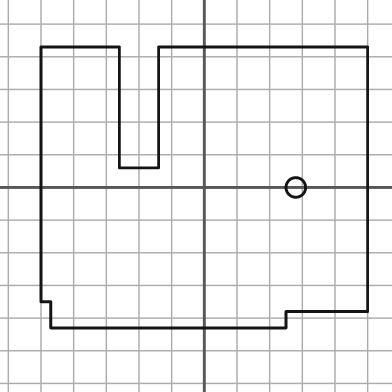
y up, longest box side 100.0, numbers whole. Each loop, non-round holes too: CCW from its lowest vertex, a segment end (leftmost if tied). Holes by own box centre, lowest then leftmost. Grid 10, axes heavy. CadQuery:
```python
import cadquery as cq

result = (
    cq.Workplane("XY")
    .moveTo(-47.0, -43.0)
    .lineTo(25.0, -43.0)
    .lineTo(25.0, -38.0)
    .lineTo(50.0, -38.0)
    .lineTo(50.0, 43.0)
    .lineTo(-14.0, 43.0)
    .lineTo(-14.0, 6.0)
    .lineTo(-26.0, 6.0)
    .lineTo(-26.0, 43.0)
    .lineTo(-50.0, 43.0)
    .lineTo(-50.0, -35.0)
    .lineTo(-47.0, -35.0)
    .close()
    .moveTo(28.0, 0.0)
    .circle(3.0)
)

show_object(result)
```